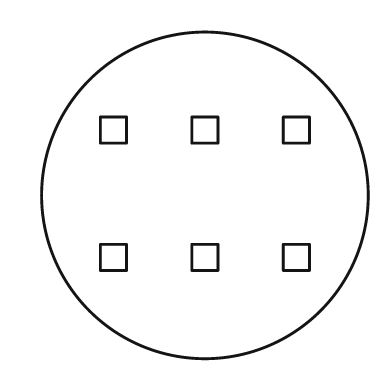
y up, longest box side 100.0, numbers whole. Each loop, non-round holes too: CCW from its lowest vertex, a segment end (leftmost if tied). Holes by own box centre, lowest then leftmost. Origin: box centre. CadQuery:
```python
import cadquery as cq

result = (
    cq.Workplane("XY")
    .moveTo(0.0, 0.0)
    .circle(50.0)
    .moveTo(-32.0, -23.0)
    .lineTo(-24.0, -23.0)
    .lineTo(-24.0, -15.0)
    .lineTo(-32.0, -15.0)
    .close()
    .moveTo(-4.0, -23.0)
    .lineTo(4.0, -23.0)
    .lineTo(4.0, -15.0)
    .lineTo(-4.0, -15.0)
    .close()
    .moveTo(24.0, -23.0)
    .lineTo(32.0, -23.0)
    .lineTo(32.0, -15.0)
    .lineTo(24.0, -15.0)
    .close()
    .moveTo(-32.0, 16.0)
    .lineTo(-24.0, 16.0)
    .lineTo(-24.0, 24.0)
    .lineTo(-32.0, 24.0)
    .close()
    .moveTo(-4.0, 16.0)
    .lineTo(4.0, 16.0)
    .lineTo(4.0, 24.0)
    .lineTo(-4.0, 24.0)
    .close()
    .moveTo(24.0, 16.0)
    .lineTo(32.0, 16.0)
    .lineTo(32.0, 24.0)
    .lineTo(24.0, 24.0)
    .close()
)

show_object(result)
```